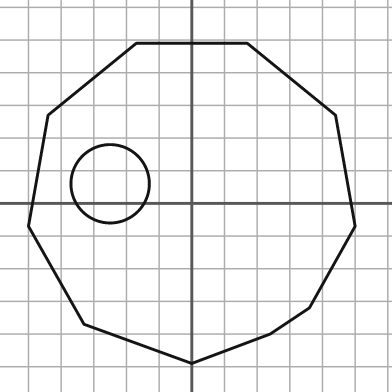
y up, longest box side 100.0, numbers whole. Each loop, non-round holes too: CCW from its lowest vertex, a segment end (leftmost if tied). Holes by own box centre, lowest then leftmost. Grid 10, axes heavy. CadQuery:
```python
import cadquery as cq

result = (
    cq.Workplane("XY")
    .moveTo(0.0, -49.0)
    .lineTo(24.0, -40.0)
    .lineTo(36.0, -32.0)
    .lineTo(50.0, -7.0)
    .lineTo(44.0, 27.0)
    .lineTo(17.0, 49.0)
    .lineTo(-17.0, 49.0)
    .lineTo(-44.0, 27.0)
    .lineTo(-50.0, -7.0)
    .lineTo(-33.0, -37.0)
    .close()
    .moveTo(-25.0, 6.0)
    .circle(12.0)
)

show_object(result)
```